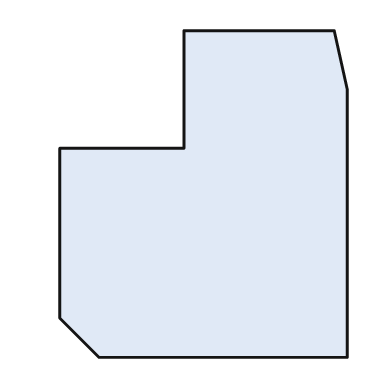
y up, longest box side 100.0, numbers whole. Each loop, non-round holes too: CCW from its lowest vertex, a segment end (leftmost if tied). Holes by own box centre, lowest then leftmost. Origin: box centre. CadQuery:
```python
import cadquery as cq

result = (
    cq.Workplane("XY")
    .moveTo(-32.0, -50.0)
    .lineTo(44.0, -50.0)
    .lineTo(44.0, 32.0)
    .lineTo(40.0, 50.0)
    .lineTo(-6.0, 50.0)
    .lineTo(-6.0, 14.0)
    .lineTo(-44.0, 14.0)
    .lineTo(-44.0, -38.0)
    .close()
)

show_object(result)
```